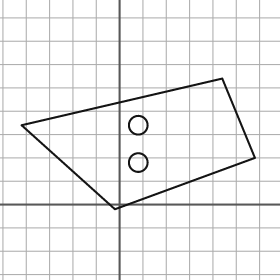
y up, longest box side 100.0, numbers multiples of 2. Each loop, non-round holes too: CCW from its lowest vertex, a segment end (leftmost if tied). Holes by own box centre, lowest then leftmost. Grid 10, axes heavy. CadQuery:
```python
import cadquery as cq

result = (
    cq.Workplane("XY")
    .moveTo(-2.0, -2.0)
    .lineTo(58.0, 20.0)
    .lineTo(44.0, 54.0)
    .lineTo(-42.0, 34.0)
    .close()
    .moveTo(8.0, 18.0)
    .circle(4.0)
    .moveTo(8.0, 34.0)
    .circle(4.0)
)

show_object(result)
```